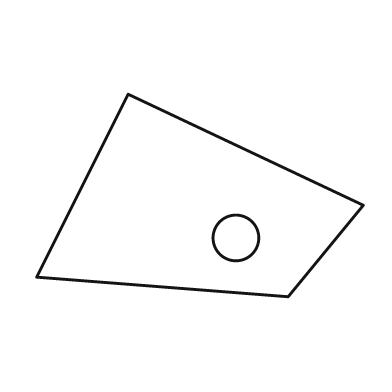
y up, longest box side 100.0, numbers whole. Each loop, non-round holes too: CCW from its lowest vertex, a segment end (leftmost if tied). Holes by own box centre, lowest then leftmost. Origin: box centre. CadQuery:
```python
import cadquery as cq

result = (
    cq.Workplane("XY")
    .moveTo(27.0, -31.0)
    .lineTo(50.0, -3.0)
    .lineTo(-22.0, 31.0)
    .lineTo(-50.0, -25.0)
    .close()
    .moveTo(11.0, -13.0)
    .circle(7.0)
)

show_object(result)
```